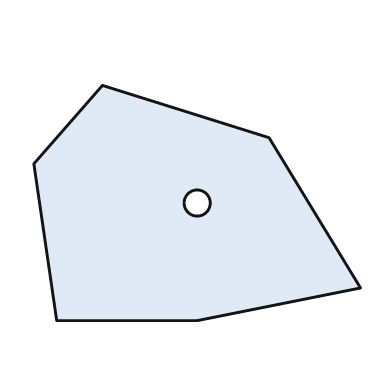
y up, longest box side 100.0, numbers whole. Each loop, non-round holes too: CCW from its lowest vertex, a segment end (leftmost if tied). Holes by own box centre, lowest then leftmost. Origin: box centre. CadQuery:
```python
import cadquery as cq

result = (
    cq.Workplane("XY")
    .moveTo(-43.0, -36.0)
    .lineTo(0.0, -36.0)
    .lineTo(50.0, -26.0)
    .lineTo(22.0, 20.0)
    .lineTo(-29.0, 36.0)
    .lineTo(-50.0, 12.0)
    .close()
    .moveTo(0.0, 0.0)
    .circle(4.0)
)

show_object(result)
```